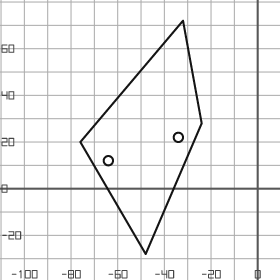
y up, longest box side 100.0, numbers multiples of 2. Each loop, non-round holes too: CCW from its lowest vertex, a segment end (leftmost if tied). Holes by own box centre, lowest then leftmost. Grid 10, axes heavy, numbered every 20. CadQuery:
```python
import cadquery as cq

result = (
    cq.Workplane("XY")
    .moveTo(-48.0, -28.0)
    .lineTo(-24.0, 28.0)
    .lineTo(-32.0, 72.0)
    .lineTo(-76.0, 20.0)
    .close()
    .moveTo(-64.0, 12.0)
    .circle(2.0)
    .moveTo(-34.0, 22.0)
    .circle(2.0)
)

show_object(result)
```